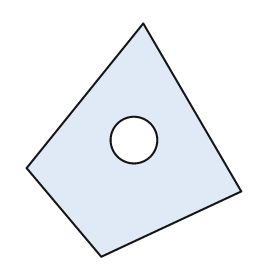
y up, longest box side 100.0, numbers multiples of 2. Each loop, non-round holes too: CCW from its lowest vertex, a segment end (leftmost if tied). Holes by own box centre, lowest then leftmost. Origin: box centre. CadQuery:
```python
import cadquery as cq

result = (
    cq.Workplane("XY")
    .moveTo(-14.0, -50.0)
    .lineTo(46.0, -22.0)
    .lineTo(4.0, 50.0)
    .lineTo(-46.0, -12.0)
    .close()
    .moveTo(0.0, 0.0)
    .circle(10.0)
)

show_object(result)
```